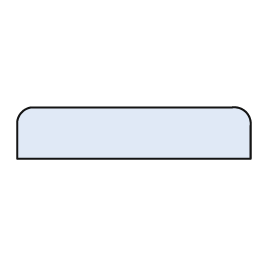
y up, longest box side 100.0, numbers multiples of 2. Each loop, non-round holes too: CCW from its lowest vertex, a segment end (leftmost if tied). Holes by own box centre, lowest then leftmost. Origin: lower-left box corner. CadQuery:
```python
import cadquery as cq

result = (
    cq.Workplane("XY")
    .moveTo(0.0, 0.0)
    .lineTo(100.0, 0.0)
    .lineTo(100.0, 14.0)
    .threePointArc((98.0, 20.0), (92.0, 22.0))
    .lineTo(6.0, 22.0)
    .threePointArc((2.0, 20.0), (0.0, 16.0))
    .close()
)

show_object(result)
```